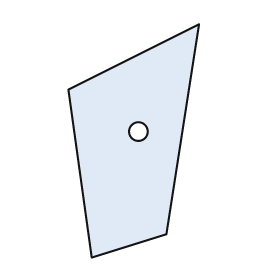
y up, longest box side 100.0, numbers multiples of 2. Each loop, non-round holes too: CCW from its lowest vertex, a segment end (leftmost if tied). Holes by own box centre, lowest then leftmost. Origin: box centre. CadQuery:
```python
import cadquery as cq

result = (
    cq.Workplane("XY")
    .moveTo(-18.0, -50.0)
    .lineTo(14.0, -40.0)
    .lineTo(28.0, 50.0)
    .lineTo(-28.0, 22.0)
    .close()
    .moveTo(2.0, 4.0)
    .circle(4.0)
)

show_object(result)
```